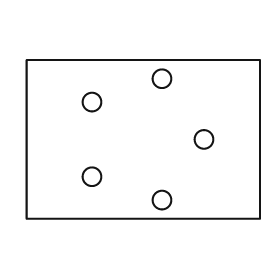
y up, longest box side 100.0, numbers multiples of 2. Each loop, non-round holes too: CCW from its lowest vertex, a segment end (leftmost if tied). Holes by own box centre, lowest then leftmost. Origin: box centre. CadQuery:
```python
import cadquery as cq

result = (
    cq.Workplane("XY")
    .moveTo(-50.0, -34.0)
    .lineTo(50.0, -34.0)
    .lineTo(50.0, 34.0)
    .lineTo(-50.0, 34.0)
    .close()
    .moveTo(8.0, -26.0)
    .circle(4.0)
    .moveTo(-22.0, -16.0)
    .circle(4.0)
    .moveTo(26.0, 0.0)
    .circle(4.0)
    .moveTo(-22.0, 16.0)
    .circle(4.0)
    .moveTo(8.0, 26.0)
    .circle(4.0)
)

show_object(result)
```